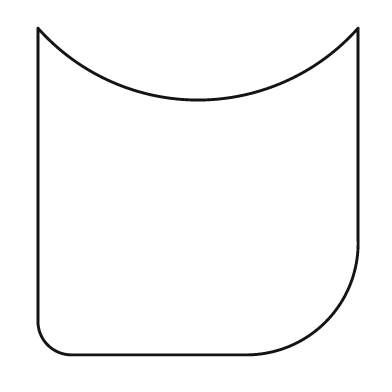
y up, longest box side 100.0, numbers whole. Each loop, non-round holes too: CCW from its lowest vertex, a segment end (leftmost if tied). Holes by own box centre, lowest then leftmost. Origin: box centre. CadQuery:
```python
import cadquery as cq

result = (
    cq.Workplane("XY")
    .moveTo(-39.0, -50.0)
    .lineTo(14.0, -50.0)
    .threePointArc((39.0, -40.0), (49.0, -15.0))
    .lineTo(49.0, 50.0)
    .threePointArc((0.0, 28.0), (-49.0, 50.0))
    .lineTo(-49.0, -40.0)
    .threePointArc((-46.0, -47.0), (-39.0, -50.0))
    .close()
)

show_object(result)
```